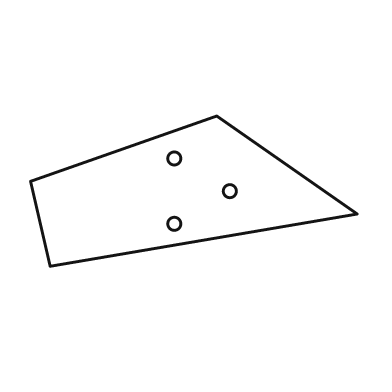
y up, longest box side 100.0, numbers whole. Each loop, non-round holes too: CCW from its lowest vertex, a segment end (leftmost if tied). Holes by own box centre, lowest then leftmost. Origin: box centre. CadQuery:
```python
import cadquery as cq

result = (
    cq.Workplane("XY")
    .moveTo(-44.0, -23.0)
    .lineTo(50.0, -7.0)
    .lineTo(7.0, 23.0)
    .lineTo(-50.0, 3.0)
    .close()
    .moveTo(-6.0, -10.0)
    .circle(2.0)
    .moveTo(11.0, 0.0)
    .circle(2.0)
    .moveTo(-6.0, 10.0)
    .circle(2.0)
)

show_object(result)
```